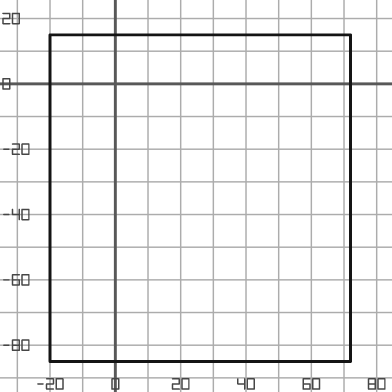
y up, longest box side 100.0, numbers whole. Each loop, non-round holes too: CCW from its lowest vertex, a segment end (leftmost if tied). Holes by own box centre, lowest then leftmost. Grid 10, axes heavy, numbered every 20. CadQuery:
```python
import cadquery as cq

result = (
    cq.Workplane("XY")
    .moveTo(-20.0, -85.0)
    .lineTo(72.0, -85.0)
    .lineTo(72.0, 15.0)
    .lineTo(-20.0, 15.0)
    .close()
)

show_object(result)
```